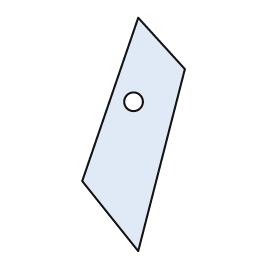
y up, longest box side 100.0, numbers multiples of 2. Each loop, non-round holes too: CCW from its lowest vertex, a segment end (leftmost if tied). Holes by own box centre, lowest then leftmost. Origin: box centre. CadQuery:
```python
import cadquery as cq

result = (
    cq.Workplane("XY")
    .moveTo(2.0, -50.0)
    .lineTo(22.0, 28.0)
    .lineTo(2.0, 50.0)
    .lineTo(-22.0, -20.0)
    .close()
    .moveTo(0.0, 14.0)
    .circle(4.0)
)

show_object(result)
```